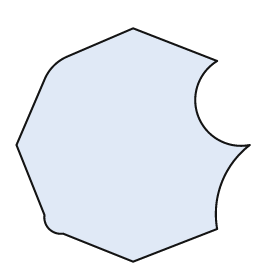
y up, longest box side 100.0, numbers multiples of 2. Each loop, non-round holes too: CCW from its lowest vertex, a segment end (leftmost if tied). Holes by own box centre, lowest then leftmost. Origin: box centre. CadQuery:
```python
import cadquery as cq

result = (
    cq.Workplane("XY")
    .moveTo(0.0, -50.0)
    .lineTo(36.0, -36.0)
    .threePointArc((38.0, -16.0), (50.0, 0.0))
    .threePointArc((28.0, 12.0), (36.0, 36.0))
    .lineTo(0.0, 50.0)
    .lineTo(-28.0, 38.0)
    .threePointArc((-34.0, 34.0), (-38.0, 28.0))
    .lineTo(-50.0, 0.0)
    .lineTo(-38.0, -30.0)
    .threePointArc((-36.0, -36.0), (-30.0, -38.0))
    .close()
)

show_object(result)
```